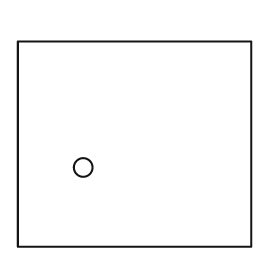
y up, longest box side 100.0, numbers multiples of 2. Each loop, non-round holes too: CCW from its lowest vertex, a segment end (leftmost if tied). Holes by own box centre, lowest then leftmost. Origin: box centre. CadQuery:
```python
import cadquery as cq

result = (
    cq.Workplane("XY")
    .moveTo(-50.0, -44.0)
    .lineTo(50.0, -44.0)
    .lineTo(50.0, 44.0)
    .lineTo(-50.0, 44.0)
    .close()
    .moveTo(-22.0, -10.0)
    .circle(4.0)
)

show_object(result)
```